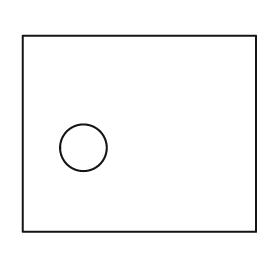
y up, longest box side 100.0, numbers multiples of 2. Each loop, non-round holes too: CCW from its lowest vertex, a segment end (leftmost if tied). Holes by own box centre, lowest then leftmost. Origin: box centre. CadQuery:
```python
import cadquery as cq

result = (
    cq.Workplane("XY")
    .moveTo(-50.0, -42.0)
    .lineTo(50.0, -42.0)
    .lineTo(50.0, 42.0)
    .lineTo(-50.0, 42.0)
    .close()
    .moveTo(-24.0, -6.0)
    .circle(10.0)
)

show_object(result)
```